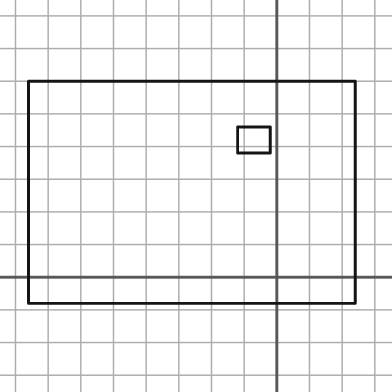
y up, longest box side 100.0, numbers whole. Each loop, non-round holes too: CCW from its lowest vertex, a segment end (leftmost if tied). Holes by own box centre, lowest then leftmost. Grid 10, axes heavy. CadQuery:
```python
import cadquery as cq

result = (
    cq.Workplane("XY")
    .moveTo(-76.0, -8.0)
    .lineTo(24.0, -8.0)
    .lineTo(24.0, 60.0)
    .lineTo(-76.0, 60.0)
    .close()
    .moveTo(-12.0, 38.0)
    .lineTo(-2.0, 38.0)
    .lineTo(-2.0, 46.0)
    .lineTo(-12.0, 46.0)
    .close()
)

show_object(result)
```